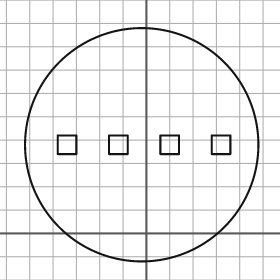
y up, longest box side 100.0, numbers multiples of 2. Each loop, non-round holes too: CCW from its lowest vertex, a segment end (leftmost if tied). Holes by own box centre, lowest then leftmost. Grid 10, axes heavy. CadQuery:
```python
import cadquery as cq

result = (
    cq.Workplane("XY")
    .moveTo(-2.0, 38.0)
    .circle(50.0)
    .moveTo(-38.0, 34.0)
    .lineTo(-30.0, 34.0)
    .lineTo(-30.0, 42.0)
    .lineTo(-38.0, 42.0)
    .close()
    .moveTo(-16.0, 34.0)
    .lineTo(-8.0, 34.0)
    .lineTo(-8.0, 42.0)
    .lineTo(-16.0, 42.0)
    .close()
    .moveTo(6.0, 34.0)
    .lineTo(14.0, 34.0)
    .lineTo(14.0, 42.0)
    .lineTo(6.0, 42.0)
    .close()
    .moveTo(28.0, 34.0)
    .lineTo(36.0, 34.0)
    .lineTo(36.0, 42.0)
    .lineTo(28.0, 42.0)
    .close()
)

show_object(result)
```